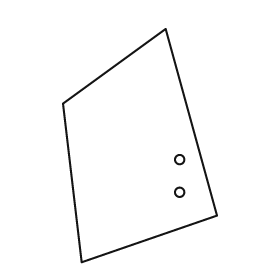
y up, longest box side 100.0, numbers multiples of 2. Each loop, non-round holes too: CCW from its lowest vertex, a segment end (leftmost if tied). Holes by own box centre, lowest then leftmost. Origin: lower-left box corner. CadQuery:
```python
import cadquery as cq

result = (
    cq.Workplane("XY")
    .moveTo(8.0, 0.0)
    .lineTo(66.0, 20.0)
    .lineTo(44.0, 100.0)
    .lineTo(0.0, 68.0)
    .close()
    .moveTo(50.0, 30.0)
    .circle(2.0)
    .moveTo(50.0, 44.0)
    .circle(2.0)
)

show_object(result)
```